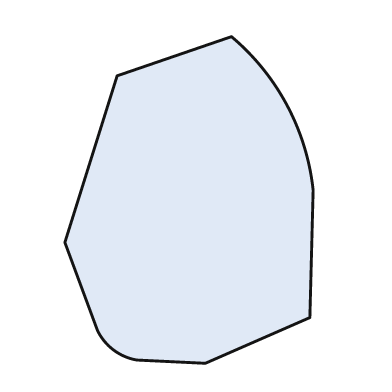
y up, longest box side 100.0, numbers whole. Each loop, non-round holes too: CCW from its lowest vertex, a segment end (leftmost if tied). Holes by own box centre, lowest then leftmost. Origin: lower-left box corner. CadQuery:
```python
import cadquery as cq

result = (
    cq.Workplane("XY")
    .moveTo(43.0, 0.0)
    .lineTo(75.0, 14.0)
    .lineTo(76.0, 53.0)
    .threePointArc((68.0, 79.0), (51.0, 100.0))
    .lineTo(16.0, 88.0)
    .lineTo(0.0, 37.0)
    .lineTo(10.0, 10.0)
    .threePointArc((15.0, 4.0), (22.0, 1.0))
    .close()
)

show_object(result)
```